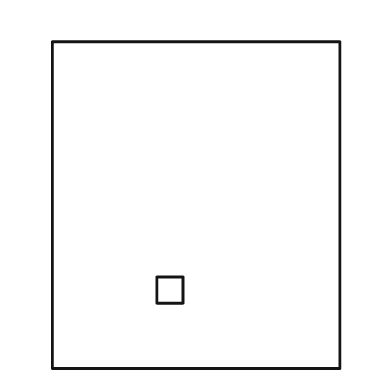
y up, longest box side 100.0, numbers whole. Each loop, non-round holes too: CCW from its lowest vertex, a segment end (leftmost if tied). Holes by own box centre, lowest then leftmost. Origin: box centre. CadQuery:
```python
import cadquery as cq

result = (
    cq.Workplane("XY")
    .moveTo(-44.0, -50.0)
    .lineTo(44.0, -50.0)
    .lineTo(44.0, 50.0)
    .lineTo(-44.0, 50.0)
    .close()
    .moveTo(-12.0, -30.0)
    .lineTo(-4.0, -30.0)
    .lineTo(-4.0, -22.0)
    .lineTo(-12.0, -22.0)
    .close()
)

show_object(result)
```